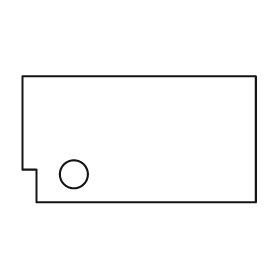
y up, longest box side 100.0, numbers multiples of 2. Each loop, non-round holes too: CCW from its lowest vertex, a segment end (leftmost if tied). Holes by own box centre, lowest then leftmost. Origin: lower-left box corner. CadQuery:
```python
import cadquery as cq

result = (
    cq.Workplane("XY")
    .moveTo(6.0, 0.0)
    .lineTo(100.0, 0.0)
    .lineTo(100.0, 54.0)
    .lineTo(0.0, 54.0)
    .lineTo(0.0, 14.0)
    .lineTo(6.0, 14.0)
    .close()
    .moveTo(22.0, 12.0)
    .circle(6.0)
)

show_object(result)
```